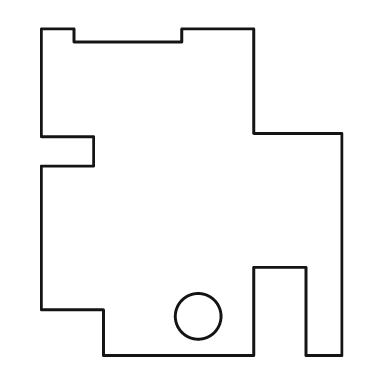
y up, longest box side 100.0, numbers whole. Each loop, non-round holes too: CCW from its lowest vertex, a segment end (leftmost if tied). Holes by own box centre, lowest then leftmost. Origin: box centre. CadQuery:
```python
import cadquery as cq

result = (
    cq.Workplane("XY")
    .moveTo(-27.0, -50.0)
    .lineTo(19.0, -50.0)
    .lineTo(19.0, -23.0)
    .lineTo(35.0, -23.0)
    .lineTo(35.0, -50.0)
    .lineTo(46.0, -50.0)
    .lineTo(46.0, 18.0)
    .lineTo(19.0, 18.0)
    .lineTo(19.0, 50.0)
    .lineTo(-3.0, 50.0)
    .lineTo(-3.0, 46.0)
    .lineTo(-36.0, 46.0)
    .lineTo(-36.0, 50.0)
    .lineTo(-46.0, 50.0)
    .lineTo(-46.0, 17.0)
    .lineTo(-30.0, 17.0)
    .lineTo(-30.0, 8.0)
    .lineTo(-46.0, 8.0)
    .lineTo(-46.0, -36.0)
    .lineTo(-27.0, -36.0)
    .close()
    .moveTo(2.0, -38.0)
    .circle(7.0)
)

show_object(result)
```